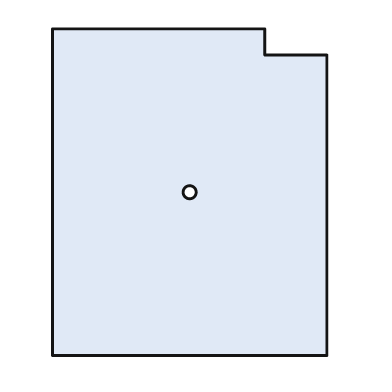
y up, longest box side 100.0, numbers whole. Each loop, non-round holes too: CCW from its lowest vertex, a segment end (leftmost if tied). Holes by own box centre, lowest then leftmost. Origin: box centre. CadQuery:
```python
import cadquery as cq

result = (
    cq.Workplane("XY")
    .moveTo(-42.0, -50.0)
    .lineTo(42.0, -50.0)
    .lineTo(42.0, 42.0)
    .lineTo(23.0, 42.0)
    .lineTo(23.0, 50.0)
    .lineTo(-42.0, 50.0)
    .close()
    .moveTo(0.0, 0.0)
    .circle(2.0)
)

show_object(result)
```